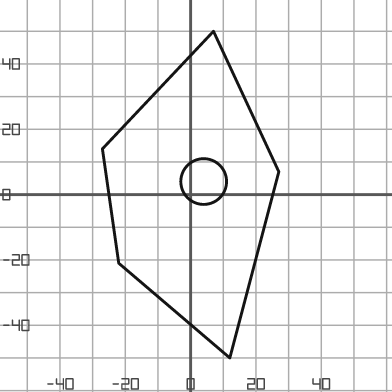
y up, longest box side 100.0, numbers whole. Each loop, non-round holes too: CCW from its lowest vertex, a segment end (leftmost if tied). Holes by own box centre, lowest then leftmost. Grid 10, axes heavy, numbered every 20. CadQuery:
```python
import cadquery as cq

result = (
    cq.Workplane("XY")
    .moveTo(12.0, -50.0)
    .lineTo(27.0, 7.0)
    .lineTo(7.0, 50.0)
    .lineTo(-27.0, 14.0)
    .lineTo(-22.0, -21.0)
    .close()
    .moveTo(4.0, 4.0)
    .circle(7.0)
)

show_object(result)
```